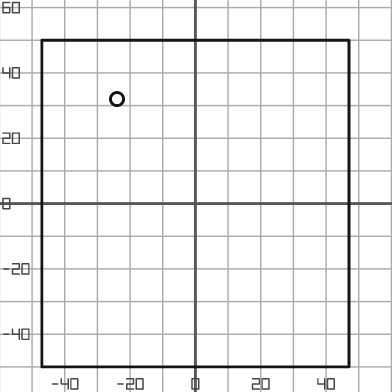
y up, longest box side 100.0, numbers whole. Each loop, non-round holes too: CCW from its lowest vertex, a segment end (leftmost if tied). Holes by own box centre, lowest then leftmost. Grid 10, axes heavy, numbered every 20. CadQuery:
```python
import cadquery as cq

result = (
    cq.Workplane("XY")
    .moveTo(-47.0, -50.0)
    .lineTo(47.0, -50.0)
    .lineTo(47.0, 50.0)
    .lineTo(-47.0, 50.0)
    .close()
    .moveTo(-24.0, 32.0)
    .circle(2.0)
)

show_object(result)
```